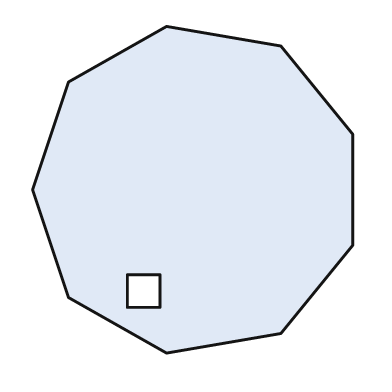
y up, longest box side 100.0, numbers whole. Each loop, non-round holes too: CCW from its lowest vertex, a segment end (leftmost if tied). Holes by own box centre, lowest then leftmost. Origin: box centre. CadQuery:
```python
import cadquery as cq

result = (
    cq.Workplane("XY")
    .moveTo(-8.0, -50.0)
    .lineTo(27.0, -44.0)
    .lineTo(49.0, -17.0)
    .lineTo(49.0, 17.0)
    .lineTo(27.0, 44.0)
    .lineTo(-8.0, 50.0)
    .lineTo(-38.0, 33.0)
    .lineTo(-49.0, 0.0)
    .lineTo(-38.0, -33.0)
    .close()
    .moveTo(-20.0, -36.0)
    .lineTo(-10.0, -36.0)
    .lineTo(-10.0, -26.0)
    .lineTo(-20.0, -26.0)
    .close()
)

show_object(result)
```